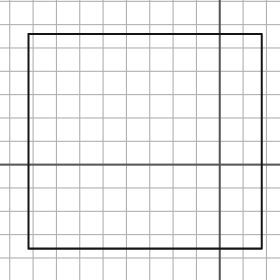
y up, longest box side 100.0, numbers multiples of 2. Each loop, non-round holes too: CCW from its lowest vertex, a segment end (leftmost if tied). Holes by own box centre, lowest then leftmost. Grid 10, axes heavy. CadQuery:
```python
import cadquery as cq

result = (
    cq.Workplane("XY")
    .moveTo(-82.0, -36.0)
    .lineTo(18.0, -36.0)
    .lineTo(18.0, 56.0)
    .lineTo(-82.0, 56.0)
    .close()
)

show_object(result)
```